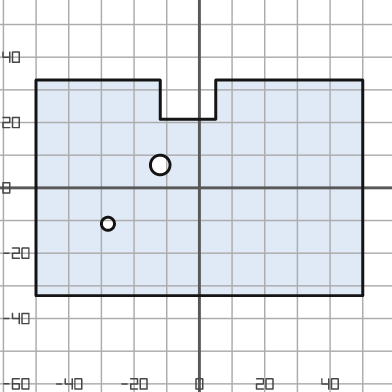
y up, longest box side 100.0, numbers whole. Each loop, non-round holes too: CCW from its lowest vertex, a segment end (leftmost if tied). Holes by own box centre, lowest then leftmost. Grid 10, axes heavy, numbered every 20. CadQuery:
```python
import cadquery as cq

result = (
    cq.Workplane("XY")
    .moveTo(-50.0, -33.0)
    .lineTo(50.0, -33.0)
    .lineTo(50.0, 33.0)
    .lineTo(5.0, 33.0)
    .lineTo(5.0, 21.0)
    .lineTo(-12.0, 21.0)
    .lineTo(-12.0, 33.0)
    .lineTo(-50.0, 33.0)
    .close()
    .moveTo(-28.0, -11.0)
    .circle(2.0)
    .moveTo(-12.0, 7.0)
    .circle(3.0)
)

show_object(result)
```